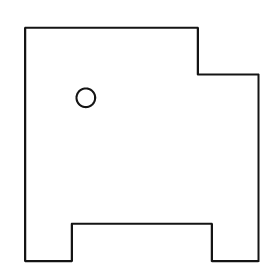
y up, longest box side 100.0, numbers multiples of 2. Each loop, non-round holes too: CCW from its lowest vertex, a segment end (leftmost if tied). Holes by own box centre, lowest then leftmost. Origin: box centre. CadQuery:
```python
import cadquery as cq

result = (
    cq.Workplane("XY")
    .moveTo(-50.0, -50.0)
    .lineTo(-30.0, -50.0)
    .lineTo(-30.0, -34.0)
    .lineTo(30.0, -34.0)
    .lineTo(30.0, -50.0)
    .lineTo(50.0, -50.0)
    .lineTo(50.0, 30.0)
    .lineTo(24.0, 30.0)
    .lineTo(24.0, 50.0)
    .lineTo(-50.0, 50.0)
    .close()
    .moveTo(-24.0, 20.0)
    .circle(4.0)
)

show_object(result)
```